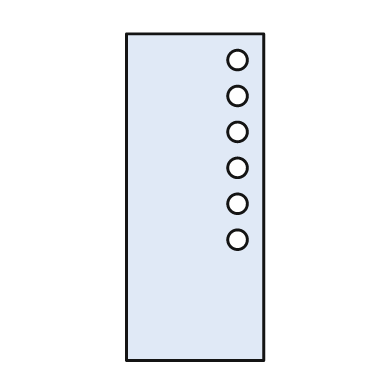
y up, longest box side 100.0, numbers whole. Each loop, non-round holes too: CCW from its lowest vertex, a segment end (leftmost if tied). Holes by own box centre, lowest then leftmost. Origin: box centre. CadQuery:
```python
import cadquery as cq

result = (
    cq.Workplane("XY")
    .moveTo(-21.0, -50.0)
    .lineTo(21.0, -50.0)
    .lineTo(21.0, 50.0)
    .lineTo(-21.0, 50.0)
    .close()
    .moveTo(13.0, -13.0)
    .circle(3.0)
    .moveTo(13.0, -2.0)
    .circle(3.0)
    .moveTo(13.0, 9.0)
    .circle(3.0)
    .moveTo(13.0, 20.0)
    .circle(3.0)
    .moveTo(13.0, 31.0)
    .circle(3.0)
    .moveTo(13.0, 42.0)
    .circle(3.0)
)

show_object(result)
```